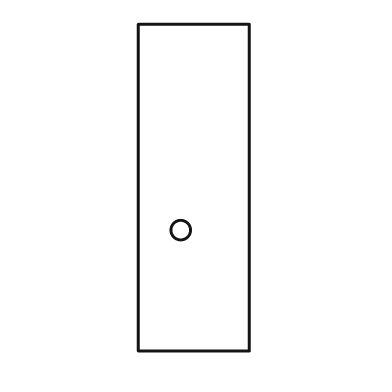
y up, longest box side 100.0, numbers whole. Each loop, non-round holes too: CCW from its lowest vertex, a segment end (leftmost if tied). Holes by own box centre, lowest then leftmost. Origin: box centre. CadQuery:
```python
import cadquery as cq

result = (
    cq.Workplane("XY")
    .moveTo(-17.0, -50.0)
    .lineTo(17.0, -50.0)
    .lineTo(17.0, 50.0)
    .lineTo(-17.0, 50.0)
    .close()
    .moveTo(-4.0, -13.0)
    .circle(3.0)
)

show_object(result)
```